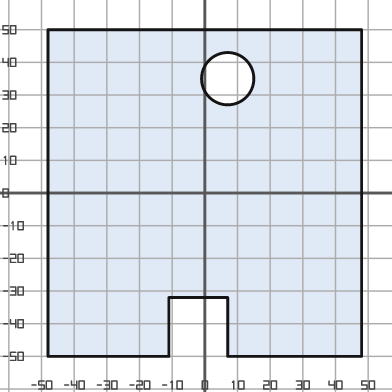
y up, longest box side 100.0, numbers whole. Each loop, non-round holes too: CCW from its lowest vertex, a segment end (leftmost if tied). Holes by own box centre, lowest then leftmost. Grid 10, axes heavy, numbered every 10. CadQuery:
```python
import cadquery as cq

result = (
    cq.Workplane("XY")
    .moveTo(-48.0, -50.0)
    .lineTo(-11.0, -50.0)
    .lineTo(-11.0, -32.0)
    .lineTo(7.0, -32.0)
    .lineTo(7.0, -50.0)
    .lineTo(48.0, -50.0)
    .lineTo(48.0, 50.0)
    .lineTo(-48.0, 50.0)
    .close()
    .moveTo(7.0, 35.0)
    .circle(8.0)
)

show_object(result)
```